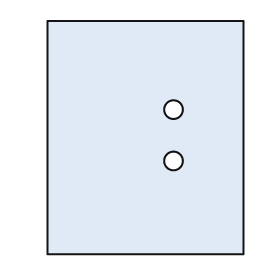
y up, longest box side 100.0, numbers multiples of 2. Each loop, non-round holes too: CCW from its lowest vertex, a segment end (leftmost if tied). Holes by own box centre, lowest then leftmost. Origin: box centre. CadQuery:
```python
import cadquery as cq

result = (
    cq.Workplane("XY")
    .moveTo(-42.0, -50.0)
    .lineTo(42.0, -50.0)
    .lineTo(42.0, 50.0)
    .lineTo(-42.0, 50.0)
    .close()
    .moveTo(12.0, -10.0)
    .circle(4.0)
    .moveTo(12.0, 12.0)
    .circle(4.0)
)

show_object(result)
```